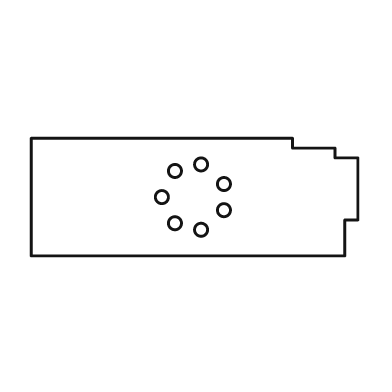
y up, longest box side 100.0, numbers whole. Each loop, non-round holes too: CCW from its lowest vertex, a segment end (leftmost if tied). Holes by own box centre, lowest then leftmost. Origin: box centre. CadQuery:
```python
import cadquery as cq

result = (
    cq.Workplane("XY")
    .moveTo(-50.0, -18.0)
    .lineTo(46.0, -18.0)
    .lineTo(46.0, -7.0)
    .lineTo(50.0, -7.0)
    .lineTo(50.0, 12.0)
    .lineTo(43.0, 12.0)
    .lineTo(43.0, 15.0)
    .lineTo(30.0, 15.0)
    .lineTo(30.0, 18.0)
    .lineTo(-50.0, 18.0)
    .close()
    .moveTo(2.0, -10.0)
    .circle(2.0)
    .moveTo(-6.0, -8.0)
    .circle(2.0)
    .moveTo(9.0, -4.0)
    .circle(2.0)
    .moveTo(-10.0, 0.0)
    .circle(2.0)
    .moveTo(9.0, 4.0)
    .circle(2.0)
    .moveTo(-6.0, 8.0)
    .circle(2.0)
    .moveTo(2.0, 10.0)
    .circle(2.0)
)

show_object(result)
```